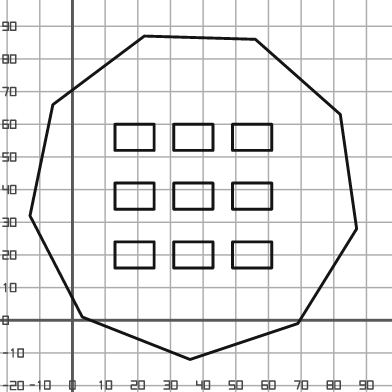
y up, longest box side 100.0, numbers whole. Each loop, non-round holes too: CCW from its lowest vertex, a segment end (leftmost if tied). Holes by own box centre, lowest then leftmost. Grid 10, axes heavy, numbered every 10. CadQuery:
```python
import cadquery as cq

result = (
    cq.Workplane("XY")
    .moveTo(36.0, -12.0)
    .lineTo(69.0, -1.0)
    .lineTo(87.0, 28.0)
    .lineTo(82.0, 63.0)
    .lineTo(56.0, 86.0)
    .lineTo(22.0, 87.0)
    .lineTo(-6.0, 66.0)
    .lineTo(-13.0, 32.0)
    .lineTo(3.0, 1.0)
    .close()
    .moveTo(13.0, 16.0)
    .lineTo(25.0, 16.0)
    .lineTo(25.0, 24.0)
    .lineTo(13.0, 24.0)
    .close()
    .moveTo(31.0, 16.0)
    .lineTo(43.0, 16.0)
    .lineTo(43.0, 24.0)
    .lineTo(31.0, 24.0)
    .close()
    .moveTo(49.0, 16.0)
    .lineTo(61.0, 16.0)
    .lineTo(61.0, 24.0)
    .lineTo(49.0, 24.0)
    .close()
    .moveTo(13.0, 34.0)
    .lineTo(25.0, 34.0)
    .lineTo(25.0, 42.0)
    .lineTo(13.0, 42.0)
    .close()
    .moveTo(31.0, 34.0)
    .lineTo(43.0, 34.0)
    .lineTo(43.0, 42.0)
    .lineTo(31.0, 42.0)
    .close()
    .moveTo(49.0, 34.0)
    .lineTo(61.0, 34.0)
    .lineTo(61.0, 42.0)
    .lineTo(49.0, 42.0)
    .close()
    .moveTo(13.0, 52.0)
    .lineTo(25.0, 52.0)
    .lineTo(25.0, 60.0)
    .lineTo(13.0, 60.0)
    .close()
    .moveTo(31.0, 52.0)
    .lineTo(43.0, 52.0)
    .lineTo(43.0, 60.0)
    .lineTo(31.0, 60.0)
    .close()
    .moveTo(49.0, 52.0)
    .lineTo(61.0, 52.0)
    .lineTo(61.0, 60.0)
    .lineTo(49.0, 60.0)
    .close()
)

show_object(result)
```